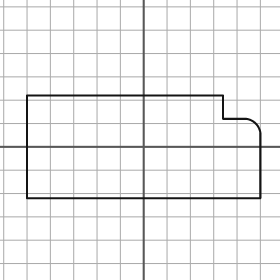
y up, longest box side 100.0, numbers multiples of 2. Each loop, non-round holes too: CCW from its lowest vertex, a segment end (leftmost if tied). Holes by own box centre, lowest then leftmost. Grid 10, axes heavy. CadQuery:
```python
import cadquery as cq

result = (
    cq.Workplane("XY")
    .moveTo(-50.0, -22.0)
    .lineTo(50.0, -22.0)
    .lineTo(50.0, 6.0)
    .threePointArc((48.0, 10.0), (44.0, 12.0))
    .lineTo(34.0, 12.0)
    .lineTo(34.0, 22.0)
    .lineTo(-50.0, 22.0)
    .close()
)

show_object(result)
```